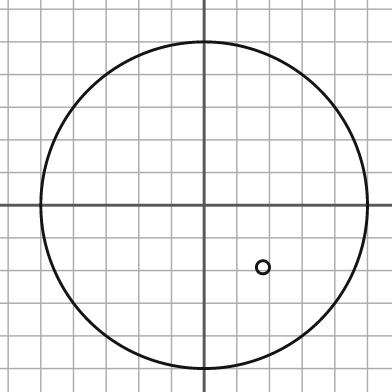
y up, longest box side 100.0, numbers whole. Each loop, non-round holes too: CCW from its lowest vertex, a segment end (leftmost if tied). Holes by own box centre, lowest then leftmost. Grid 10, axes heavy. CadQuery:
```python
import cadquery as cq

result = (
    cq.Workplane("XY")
    .moveTo(0.0, 0.0)
    .circle(50.0)
    .moveTo(18.0, -19.0)
    .circle(2.0)
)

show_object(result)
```